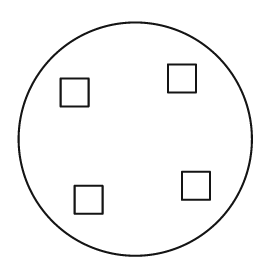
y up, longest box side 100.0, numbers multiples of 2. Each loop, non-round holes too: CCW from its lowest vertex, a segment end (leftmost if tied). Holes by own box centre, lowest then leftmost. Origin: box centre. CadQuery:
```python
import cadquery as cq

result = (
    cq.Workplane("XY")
    .moveTo(0.0, 0.0)
    .circle(50.0)
    .moveTo(-26.0, -32.0)
    .lineTo(-14.0, -32.0)
    .lineTo(-14.0, -20.0)
    .lineTo(-26.0, -20.0)
    .close()
    .moveTo(20.0, -26.0)
    .lineTo(32.0, -26.0)
    .lineTo(32.0, -14.0)
    .lineTo(20.0, -14.0)
    .close()
    .moveTo(-32.0, 14.0)
    .lineTo(-20.0, 14.0)
    .lineTo(-20.0, 26.0)
    .lineTo(-32.0, 26.0)
    .close()
    .moveTo(14.0, 20.0)
    .lineTo(26.0, 20.0)
    .lineTo(26.0, 32.0)
    .lineTo(14.0, 32.0)
    .close()
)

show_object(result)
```